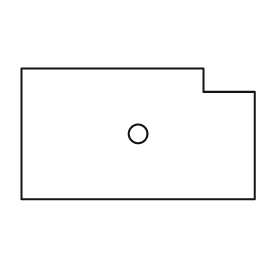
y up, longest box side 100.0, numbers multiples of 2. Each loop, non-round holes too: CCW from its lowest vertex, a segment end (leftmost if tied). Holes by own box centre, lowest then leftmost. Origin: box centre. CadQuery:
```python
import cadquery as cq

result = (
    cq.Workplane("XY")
    .moveTo(-50.0, -28.0)
    .lineTo(50.0, -28.0)
    .lineTo(50.0, 18.0)
    .lineTo(28.0, 18.0)
    .lineTo(28.0, 28.0)
    .lineTo(-50.0, 28.0)
    .close()
    .moveTo(0.0, 0.0)
    .circle(4.0)
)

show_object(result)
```